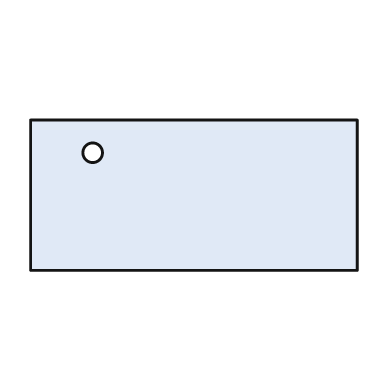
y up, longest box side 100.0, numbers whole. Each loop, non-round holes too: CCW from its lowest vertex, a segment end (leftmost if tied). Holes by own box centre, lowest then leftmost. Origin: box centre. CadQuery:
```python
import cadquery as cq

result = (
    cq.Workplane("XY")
    .moveTo(-50.0, -23.0)
    .lineTo(50.0, -23.0)
    .lineTo(50.0, 23.0)
    .lineTo(-50.0, 23.0)
    .close()
    .moveTo(-31.0, 13.0)
    .circle(3.0)
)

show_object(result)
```